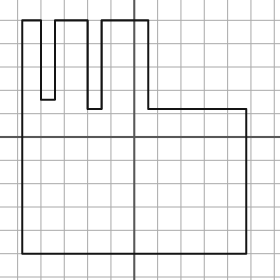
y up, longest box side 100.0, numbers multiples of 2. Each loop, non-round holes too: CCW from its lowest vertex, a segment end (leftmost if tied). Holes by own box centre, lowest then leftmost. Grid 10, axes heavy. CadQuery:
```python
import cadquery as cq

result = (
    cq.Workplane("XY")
    .moveTo(-48.0, -50.0)
    .lineTo(48.0, -50.0)
    .lineTo(48.0, 12.0)
    .lineTo(6.0, 12.0)
    .lineTo(6.0, 50.0)
    .lineTo(-14.0, 50.0)
    .lineTo(-14.0, 12.0)
    .lineTo(-20.0, 12.0)
    .lineTo(-20.0, 50.0)
    .lineTo(-34.0, 50.0)
    .lineTo(-34.0, 16.0)
    .lineTo(-40.0, 16.0)
    .lineTo(-40.0, 50.0)
    .lineTo(-48.0, 50.0)
    .close()
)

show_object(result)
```